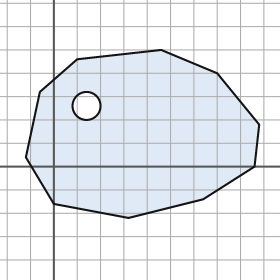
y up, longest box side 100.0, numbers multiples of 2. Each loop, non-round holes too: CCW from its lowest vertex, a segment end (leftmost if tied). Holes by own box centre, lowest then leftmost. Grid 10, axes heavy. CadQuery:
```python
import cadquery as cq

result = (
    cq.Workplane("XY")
    .moveTo(32.0, -22.0)
    .lineTo(64.0, -14.0)
    .lineTo(86.0, 0.0)
    .lineTo(88.0, 18.0)
    .lineTo(70.0, 40.0)
    .lineTo(46.0, 50.0)
    .lineTo(10.0, 46.0)
    .lineTo(-6.0, 32.0)
    .lineTo(-12.0, 4.0)
    .lineTo(0.0, -16.0)
    .close()
    .moveTo(14.0, 26.0)
    .circle(6.0)
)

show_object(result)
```